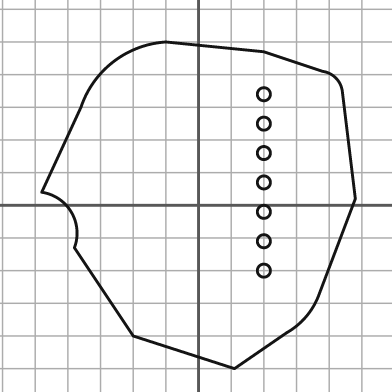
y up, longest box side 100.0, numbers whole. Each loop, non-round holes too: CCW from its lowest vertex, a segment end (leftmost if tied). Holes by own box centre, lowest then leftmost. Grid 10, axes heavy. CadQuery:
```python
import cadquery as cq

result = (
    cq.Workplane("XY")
    .moveTo(11.0, -50.0)
    .lineTo(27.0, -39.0)
    .threePointArc((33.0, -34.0), (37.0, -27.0))
    .lineTo(48.0, 2.0)
    .lineTo(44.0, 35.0)
    .threePointArc((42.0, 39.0), (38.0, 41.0))
    .lineTo(20.0, 47.0)
    .lineTo(-10.0, 50.0)
    .threePointArc((-26.0, 44.0), (-36.0, 30.0))
    .lineTo(-48.0, 4.0)
    .threePointArc((-39.0, -2.0), (-38.0, -13.0))
    .lineTo(-20.0, -40.0)
    .close()
    .moveTo(20.0, -20.0)
    .circle(2.0)
    .moveTo(20.0, -11.0)
    .circle(2.0)
    .moveTo(20.0, -2.0)
    .circle(2.0)
    .moveTo(20.0, 7.0)
    .circle(2.0)
    .moveTo(20.0, 16.0)
    .circle(2.0)
    .moveTo(20.0, 25.0)
    .circle(2.0)
    .moveTo(20.0, 34.0)
    .circle(2.0)
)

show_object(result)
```